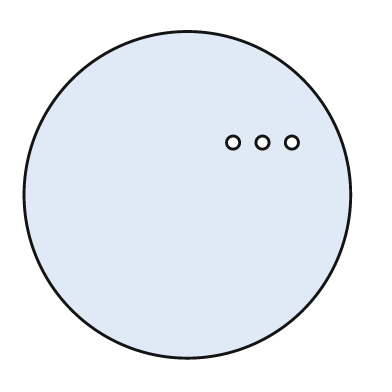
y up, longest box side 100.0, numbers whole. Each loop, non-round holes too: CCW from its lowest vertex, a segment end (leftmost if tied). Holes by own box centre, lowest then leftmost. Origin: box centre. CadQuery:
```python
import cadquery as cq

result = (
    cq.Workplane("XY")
    .moveTo(0.0, 0.0)
    .circle(50.0)
    .moveTo(14.0, 16.0)
    .circle(2.0)
    .moveTo(23.0, 16.0)
    .circle(2.0)
    .moveTo(32.0, 16.0)
    .circle(2.0)
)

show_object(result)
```